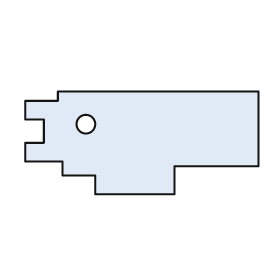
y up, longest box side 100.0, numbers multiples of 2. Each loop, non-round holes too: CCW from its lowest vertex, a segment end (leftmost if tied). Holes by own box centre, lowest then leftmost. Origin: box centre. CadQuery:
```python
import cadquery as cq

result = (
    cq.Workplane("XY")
    .moveTo(-20.0, -22.0)
    .lineTo(14.0, -22.0)
    .lineTo(14.0, -10.0)
    .lineTo(50.0, -10.0)
    .lineTo(50.0, 22.0)
    .lineTo(-36.0, 22.0)
    .lineTo(-36.0, 18.0)
    .lineTo(-50.0, 18.0)
    .lineTo(-50.0, 10.0)
    .lineTo(-42.0, 10.0)
    .lineTo(-42.0, 0.0)
    .lineTo(-50.0, 0.0)
    .lineTo(-50.0, -8.0)
    .lineTo(-34.0, -8.0)
    .lineTo(-34.0, -14.0)
    .lineTo(-20.0, -14.0)
    .close()
    .moveTo(-24.0, 8.0)
    .circle(4.0)
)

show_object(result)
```